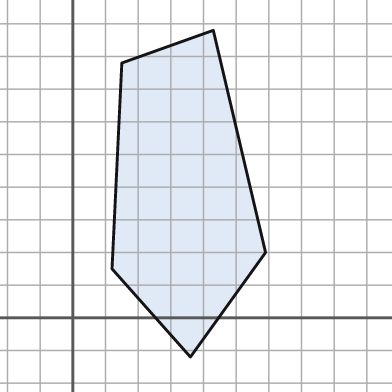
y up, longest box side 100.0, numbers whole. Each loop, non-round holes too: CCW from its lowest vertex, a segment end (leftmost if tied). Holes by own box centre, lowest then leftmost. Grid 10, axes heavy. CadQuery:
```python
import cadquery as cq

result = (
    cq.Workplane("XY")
    .moveTo(36.0, -12.0)
    .lineTo(59.0, 20.0)
    .lineTo(43.0, 88.0)
    .lineTo(15.0, 78.0)
    .lineTo(12.0, 15.0)
    .close()
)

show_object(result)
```